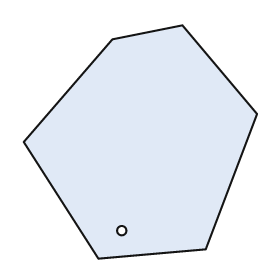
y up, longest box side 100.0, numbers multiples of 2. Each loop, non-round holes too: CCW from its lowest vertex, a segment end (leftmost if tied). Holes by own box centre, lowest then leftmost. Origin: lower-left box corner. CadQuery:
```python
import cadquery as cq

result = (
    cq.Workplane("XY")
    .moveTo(32.0, 0.0)
    .lineTo(78.0, 4.0)
    .lineTo(100.0, 62.0)
    .lineTo(68.0, 100.0)
    .lineTo(38.0, 94.0)
    .lineTo(0.0, 50.0)
    .close()
    .moveTo(42.0, 12.0)
    .circle(2.0)
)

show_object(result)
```